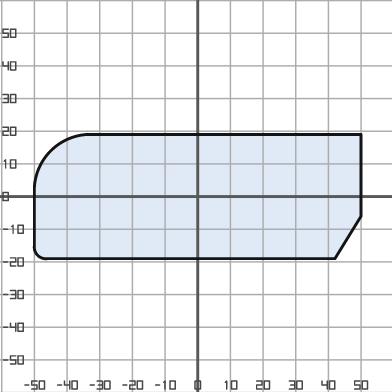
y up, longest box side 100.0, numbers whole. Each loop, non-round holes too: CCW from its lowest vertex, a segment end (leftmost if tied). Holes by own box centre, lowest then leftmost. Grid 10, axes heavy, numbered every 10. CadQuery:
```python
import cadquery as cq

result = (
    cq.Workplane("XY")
    .moveTo(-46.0, -19.0)
    .lineTo(42.0, -19.0)
    .lineTo(50.0, -6.0)
    .lineTo(50.0, 19.0)
    .lineTo(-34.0, 19.0)
    .threePointArc((-45.0, 14.0), (-50.0, 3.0))
    .lineTo(-50.0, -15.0)
    .threePointArc((-49.0, -18.0), (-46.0, -19.0))
    .close()
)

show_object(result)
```